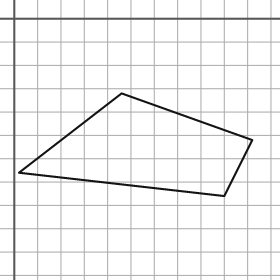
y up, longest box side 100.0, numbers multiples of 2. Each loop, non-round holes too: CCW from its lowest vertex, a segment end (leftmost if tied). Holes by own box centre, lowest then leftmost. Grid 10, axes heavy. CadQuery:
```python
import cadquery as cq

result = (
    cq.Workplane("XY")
    .moveTo(90.0, -76.0)
    .lineTo(102.0, -52.0)
    .lineTo(46.0, -32.0)
    .lineTo(2.0, -66.0)
    .close()
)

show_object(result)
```